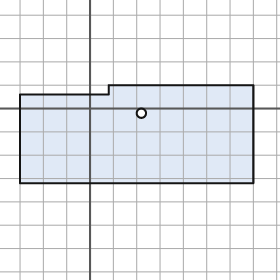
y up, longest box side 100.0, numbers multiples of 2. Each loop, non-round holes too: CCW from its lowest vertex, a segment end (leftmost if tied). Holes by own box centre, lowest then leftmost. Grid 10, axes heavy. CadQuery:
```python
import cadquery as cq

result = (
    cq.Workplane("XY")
    .moveTo(-30.0, -32.0)
    .lineTo(70.0, -32.0)
    .lineTo(70.0, 10.0)
    .lineTo(8.0, 10.0)
    .lineTo(8.0, 6.0)
    .lineTo(-30.0, 6.0)
    .close()
    .moveTo(22.0, -2.0)
    .circle(2.0)
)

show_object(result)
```